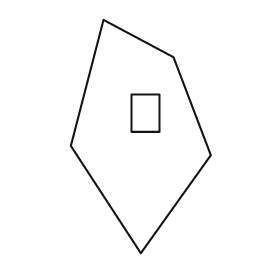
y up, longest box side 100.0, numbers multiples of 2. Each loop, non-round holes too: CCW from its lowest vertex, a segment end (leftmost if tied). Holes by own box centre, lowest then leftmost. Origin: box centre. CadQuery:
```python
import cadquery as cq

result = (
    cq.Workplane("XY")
    .moveTo(0.0, -50.0)
    .lineTo(30.0, -8.0)
    .lineTo(14.0, 34.0)
    .lineTo(-16.0, 50.0)
    .lineTo(-30.0, -4.0)
    .close()
    .moveTo(-4.0, 2.0)
    .lineTo(8.0, 2.0)
    .lineTo(8.0, 18.0)
    .lineTo(-4.0, 18.0)
    .close()
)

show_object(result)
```